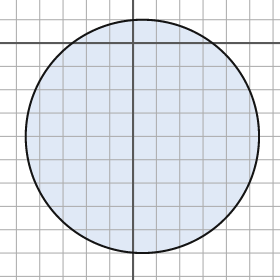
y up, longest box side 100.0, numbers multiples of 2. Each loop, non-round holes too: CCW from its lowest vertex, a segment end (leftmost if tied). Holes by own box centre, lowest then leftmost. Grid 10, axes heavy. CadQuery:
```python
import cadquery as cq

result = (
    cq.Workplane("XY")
    .moveTo(4.0, -40.0)
    .circle(50.0)
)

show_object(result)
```